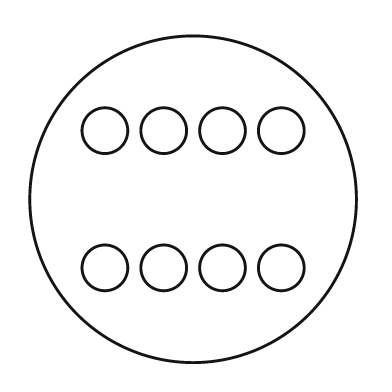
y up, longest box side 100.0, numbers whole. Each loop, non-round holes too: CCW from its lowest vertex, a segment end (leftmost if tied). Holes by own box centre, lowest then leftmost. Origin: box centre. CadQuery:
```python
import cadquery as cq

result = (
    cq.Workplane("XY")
    .moveTo(0.0, 0.0)
    .circle(50.0)
    .moveTo(-27.0, -21.0)
    .circle(7.0)
    .moveTo(-9.0, -21.0)
    .circle(7.0)
    .moveTo(9.0, -21.0)
    .circle(7.0)
    .moveTo(27.0, -21.0)
    .circle(7.0)
    .moveTo(-27.0, 21.0)
    .circle(7.0)
    .moveTo(-9.0, 21.0)
    .circle(7.0)
    .moveTo(9.0, 21.0)
    .circle(7.0)
    .moveTo(27.0, 21.0)
    .circle(7.0)
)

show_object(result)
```